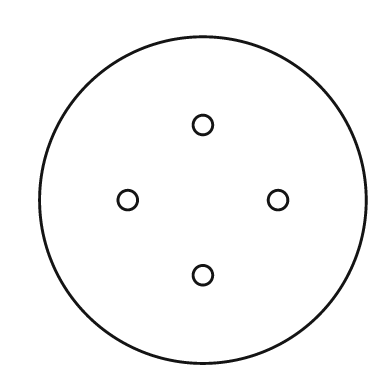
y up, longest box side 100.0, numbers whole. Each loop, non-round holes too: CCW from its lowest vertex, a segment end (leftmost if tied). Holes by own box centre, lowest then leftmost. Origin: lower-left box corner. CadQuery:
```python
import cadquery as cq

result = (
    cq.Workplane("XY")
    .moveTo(50.0, 50.0)
    .circle(50.0)
    .moveTo(50.0, 27.0)
    .circle(3.0)
    .moveTo(27.0, 50.0)
    .circle(3.0)
    .moveTo(73.0, 50.0)
    .circle(3.0)
    .moveTo(50.0, 73.0)
    .circle(3.0)
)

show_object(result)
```